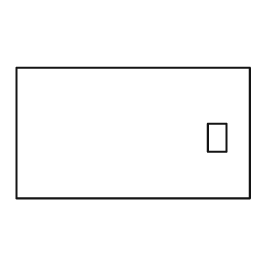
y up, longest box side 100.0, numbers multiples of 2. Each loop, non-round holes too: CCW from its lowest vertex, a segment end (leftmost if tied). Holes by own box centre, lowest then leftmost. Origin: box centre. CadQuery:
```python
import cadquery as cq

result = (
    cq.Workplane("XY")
    .moveTo(-50.0, -28.0)
    .lineTo(50.0, -28.0)
    .lineTo(50.0, 28.0)
    .lineTo(-50.0, 28.0)
    .close()
    .moveTo(32.0, -8.0)
    .lineTo(40.0, -8.0)
    .lineTo(40.0, 4.0)
    .lineTo(32.0, 4.0)
    .close()
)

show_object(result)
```